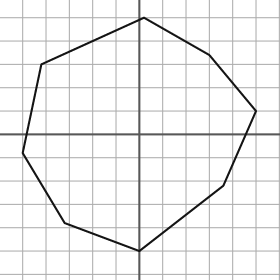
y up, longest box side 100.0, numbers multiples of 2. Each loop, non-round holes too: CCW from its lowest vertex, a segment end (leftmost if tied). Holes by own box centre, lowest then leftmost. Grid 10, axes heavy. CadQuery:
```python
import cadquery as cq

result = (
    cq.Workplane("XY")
    .moveTo(0.0, -50.0)
    .lineTo(36.0, -22.0)
    .lineTo(50.0, 10.0)
    .lineTo(30.0, 34.0)
    .lineTo(2.0, 50.0)
    .lineTo(-42.0, 30.0)
    .lineTo(-50.0, -8.0)
    .lineTo(-32.0, -38.0)
    .close()
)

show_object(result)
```